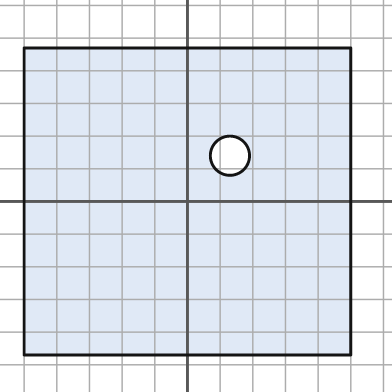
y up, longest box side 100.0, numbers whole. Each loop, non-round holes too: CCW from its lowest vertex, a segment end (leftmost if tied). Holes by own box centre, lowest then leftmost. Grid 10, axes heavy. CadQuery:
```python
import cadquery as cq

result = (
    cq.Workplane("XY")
    .moveTo(-50.0, -47.0)
    .lineTo(50.0, -47.0)
    .lineTo(50.0, 47.0)
    .lineTo(-50.0, 47.0)
    .close()
    .moveTo(13.0, 14.0)
    .circle(6.0)
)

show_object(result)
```